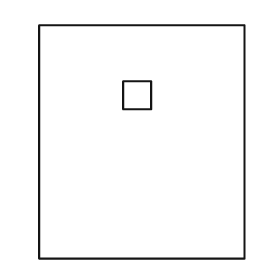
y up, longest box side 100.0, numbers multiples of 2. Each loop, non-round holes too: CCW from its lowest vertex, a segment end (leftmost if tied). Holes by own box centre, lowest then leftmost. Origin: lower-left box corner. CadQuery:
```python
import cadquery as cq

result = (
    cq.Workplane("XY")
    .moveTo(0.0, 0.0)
    .lineTo(88.0, 0.0)
    .lineTo(88.0, 100.0)
    .lineTo(0.0, 100.0)
    .close()
    .moveTo(36.0, 64.0)
    .lineTo(48.0, 64.0)
    .lineTo(48.0, 76.0)
    .lineTo(36.0, 76.0)
    .close()
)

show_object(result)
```